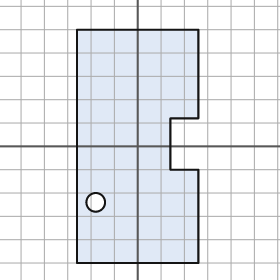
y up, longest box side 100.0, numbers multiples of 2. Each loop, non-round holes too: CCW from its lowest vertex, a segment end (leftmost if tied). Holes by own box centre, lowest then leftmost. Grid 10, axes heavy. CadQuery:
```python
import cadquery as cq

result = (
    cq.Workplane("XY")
    .moveTo(-26.0, -50.0)
    .lineTo(26.0, -50.0)
    .lineTo(26.0, -10.0)
    .lineTo(14.0, -10.0)
    .lineTo(14.0, 12.0)
    .lineTo(26.0, 12.0)
    .lineTo(26.0, 50.0)
    .lineTo(-26.0, 50.0)
    .close()
    .moveTo(-18.0, -24.0)
    .circle(4.0)
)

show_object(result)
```